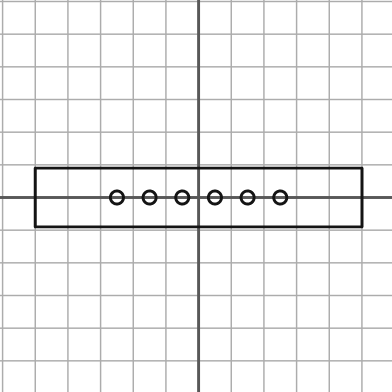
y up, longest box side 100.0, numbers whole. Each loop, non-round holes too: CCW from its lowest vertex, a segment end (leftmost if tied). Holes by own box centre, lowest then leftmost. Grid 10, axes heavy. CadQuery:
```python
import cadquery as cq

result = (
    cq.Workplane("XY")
    .moveTo(-50.0, -9.0)
    .lineTo(50.0, -9.0)
    .lineTo(50.0, 9.0)
    .lineTo(-50.0, 9.0)
    .close()
    .moveTo(-25.0, 0.0)
    .circle(2.0)
    .moveTo(-15.0, 0.0)
    .circle(2.0)
    .moveTo(-5.0, 0.0)
    .circle(2.0)
    .moveTo(5.0, 0.0)
    .circle(2.0)
    .moveTo(15.0, 0.0)
    .circle(2.0)
    .moveTo(25.0, 0.0)
    .circle(2.0)
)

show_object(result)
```